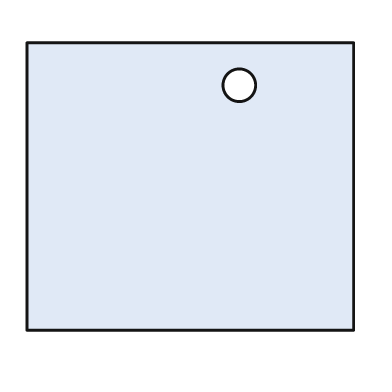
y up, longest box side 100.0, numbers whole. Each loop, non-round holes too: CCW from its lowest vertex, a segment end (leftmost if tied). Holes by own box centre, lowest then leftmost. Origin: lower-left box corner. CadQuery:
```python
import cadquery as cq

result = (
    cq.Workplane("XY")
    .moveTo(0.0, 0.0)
    .lineTo(100.0, 0.0)
    .lineTo(100.0, 88.0)
    .lineTo(0.0, 88.0)
    .close()
    .moveTo(65.0, 75.0)
    .circle(5.0)
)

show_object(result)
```